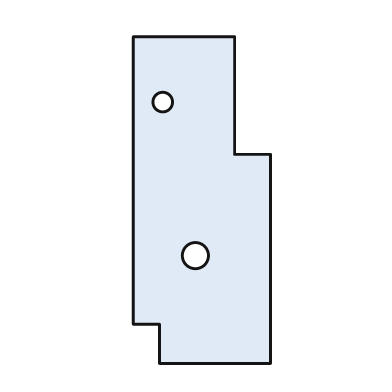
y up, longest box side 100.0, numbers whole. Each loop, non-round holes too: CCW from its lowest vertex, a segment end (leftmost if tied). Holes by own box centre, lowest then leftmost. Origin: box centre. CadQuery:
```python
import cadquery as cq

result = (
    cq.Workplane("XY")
    .moveTo(-13.0, -50.0)
    .lineTo(21.0, -50.0)
    .lineTo(21.0, 14.0)
    .lineTo(10.0, 14.0)
    .lineTo(10.0, 50.0)
    .lineTo(-21.0, 50.0)
    .lineTo(-21.0, -38.0)
    .lineTo(-13.0, -38.0)
    .close()
    .moveTo(-2.0, -17.0)
    .circle(4.0)
    .moveTo(-12.0, 30.0)
    .circle(3.0)
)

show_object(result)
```